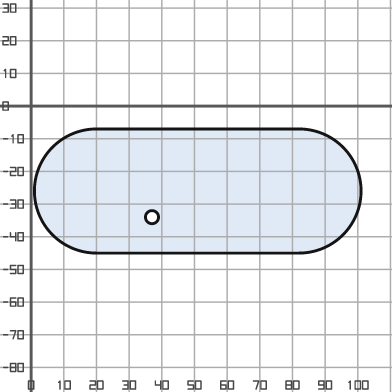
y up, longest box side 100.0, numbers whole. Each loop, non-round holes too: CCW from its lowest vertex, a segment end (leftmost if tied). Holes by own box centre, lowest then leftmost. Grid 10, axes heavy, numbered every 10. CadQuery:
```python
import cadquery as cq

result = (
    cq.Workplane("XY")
    .moveTo(20.0, -45.0)
    .lineTo(82.0, -45.0)
    .threePointArc((101.0, -26.0), (82.0, -7.0))
    .lineTo(20.0, -7.0)
    .threePointArc((1.0, -26.0), (20.0, -45.0))
    .close()
    .moveTo(37.0, -34.0)
    .circle(2.0)
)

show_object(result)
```